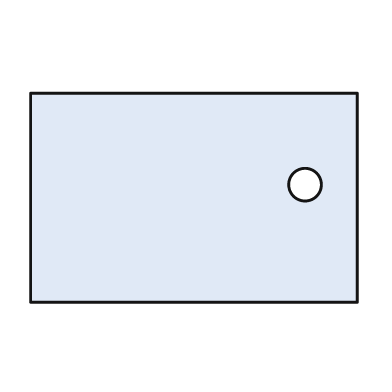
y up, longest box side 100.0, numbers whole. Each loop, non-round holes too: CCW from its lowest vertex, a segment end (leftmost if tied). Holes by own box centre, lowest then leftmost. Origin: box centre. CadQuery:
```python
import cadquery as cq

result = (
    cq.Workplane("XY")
    .moveTo(-50.0, -32.0)
    .lineTo(50.0, -32.0)
    .lineTo(50.0, 32.0)
    .lineTo(-50.0, 32.0)
    .close()
    .moveTo(34.0, 4.0)
    .circle(5.0)
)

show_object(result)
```